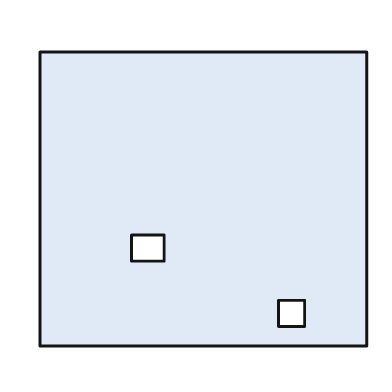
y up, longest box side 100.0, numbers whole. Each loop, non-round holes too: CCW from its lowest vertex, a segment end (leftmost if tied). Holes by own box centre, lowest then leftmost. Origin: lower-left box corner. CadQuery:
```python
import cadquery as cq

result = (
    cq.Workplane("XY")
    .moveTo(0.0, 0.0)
    .lineTo(100.0, 0.0)
    .lineTo(100.0, 90.0)
    .lineTo(0.0, 90.0)
    .close()
    .moveTo(73.0, 6.0)
    .lineTo(81.0, 6.0)
    .lineTo(81.0, 14.0)
    .lineTo(73.0, 14.0)
    .close()
    .moveTo(28.0, 26.0)
    .lineTo(38.0, 26.0)
    .lineTo(38.0, 34.0)
    .lineTo(28.0, 34.0)
    .close()
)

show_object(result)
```